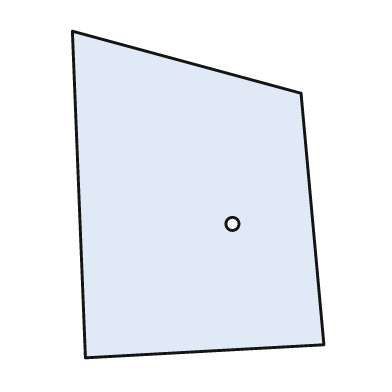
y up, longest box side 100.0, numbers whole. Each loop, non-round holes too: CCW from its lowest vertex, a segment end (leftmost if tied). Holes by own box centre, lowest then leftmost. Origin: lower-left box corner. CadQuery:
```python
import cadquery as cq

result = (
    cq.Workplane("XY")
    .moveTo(4.0, 0.0)
    .lineTo(77.0, 4.0)
    .lineTo(70.0, 81.0)
    .lineTo(0.0, 100.0)
    .close()
    .moveTo(49.0, 41.0)
    .circle(2.0)
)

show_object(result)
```